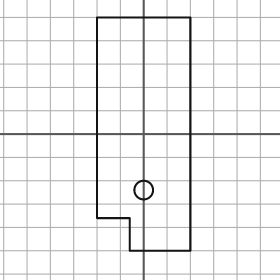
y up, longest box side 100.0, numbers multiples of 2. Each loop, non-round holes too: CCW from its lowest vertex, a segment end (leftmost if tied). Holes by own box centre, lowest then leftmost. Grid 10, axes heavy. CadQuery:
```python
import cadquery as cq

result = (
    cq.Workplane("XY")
    .moveTo(-6.0, -50.0)
    .lineTo(20.0, -50.0)
    .lineTo(20.0, 50.0)
    .lineTo(-20.0, 50.0)
    .lineTo(-20.0, -36.0)
    .lineTo(-6.0, -36.0)
    .close()
    .moveTo(0.0, -24.0)
    .circle(4.0)
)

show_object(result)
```